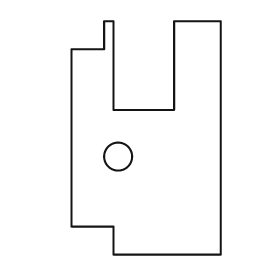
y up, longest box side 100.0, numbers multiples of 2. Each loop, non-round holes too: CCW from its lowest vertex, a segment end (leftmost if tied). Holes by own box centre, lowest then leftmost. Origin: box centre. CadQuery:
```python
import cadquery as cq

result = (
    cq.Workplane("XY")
    .moveTo(-14.0, -50.0)
    .lineTo(32.0, -50.0)
    .lineTo(32.0, 50.0)
    .lineTo(12.0, 50.0)
    .lineTo(12.0, 12.0)
    .lineTo(-14.0, 12.0)
    .lineTo(-14.0, 50.0)
    .lineTo(-18.0, 50.0)
    .lineTo(-18.0, 38.0)
    .lineTo(-32.0, 38.0)
    .lineTo(-32.0, -38.0)
    .lineTo(-14.0, -38.0)
    .close()
    .moveTo(-12.0, -8.0)
    .circle(6.0)
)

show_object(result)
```